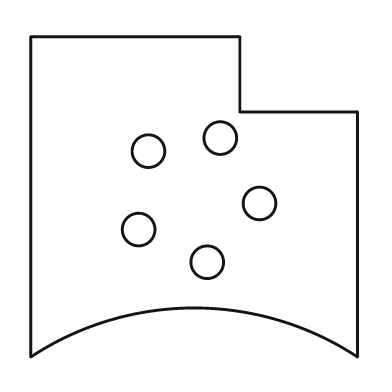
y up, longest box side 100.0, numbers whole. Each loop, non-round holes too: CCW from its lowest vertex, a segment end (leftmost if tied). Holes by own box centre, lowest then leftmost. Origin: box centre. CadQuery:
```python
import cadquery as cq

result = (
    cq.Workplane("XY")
    .moveTo(-50.0, -49.0)
    .threePointArc((0.0, -34.0), (50.0, -49.0))
    .lineTo(50.0, 26.0)
    .lineTo(14.0, 26.0)
    .lineTo(14.0, 49.0)
    .lineTo(-50.0, 49.0)
    .close()
    .moveTo(4.0, -20.0)
    .circle(5.0)
    .moveTo(-17.0, -10.0)
    .circle(5.0)
    .moveTo(20.0, -2.0)
    .circle(5.0)
    .moveTo(-14.0, 14.0)
    .circle(5.0)
    .moveTo(8.0, 18.0)
    .circle(5.0)
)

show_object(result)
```